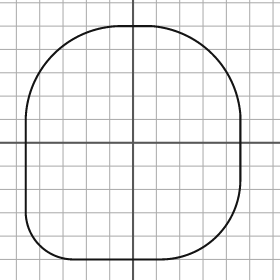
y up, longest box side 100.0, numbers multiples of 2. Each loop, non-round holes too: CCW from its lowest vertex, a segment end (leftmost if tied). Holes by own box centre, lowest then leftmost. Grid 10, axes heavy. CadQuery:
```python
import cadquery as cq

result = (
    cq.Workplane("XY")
    .moveTo(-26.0, -50.0)
    .lineTo(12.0, -50.0)
    .threePointArc((36.0, -40.0), (46.0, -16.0))
    .lineTo(46.0, 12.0)
    .threePointArc((34.0, 38.0), (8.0, 50.0))
    .lineTo(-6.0, 50.0)
    .threePointArc((-34.0, 38.0), (-46.0, 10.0))
    .lineTo(-46.0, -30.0)
    .threePointArc((-40.0, -44.0), (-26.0, -50.0))
    .close()
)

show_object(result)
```